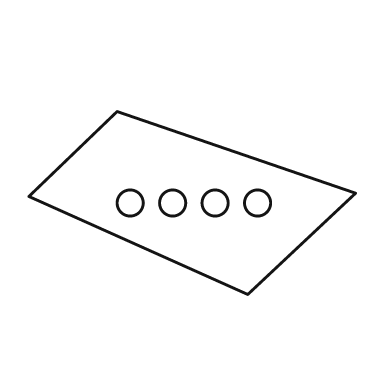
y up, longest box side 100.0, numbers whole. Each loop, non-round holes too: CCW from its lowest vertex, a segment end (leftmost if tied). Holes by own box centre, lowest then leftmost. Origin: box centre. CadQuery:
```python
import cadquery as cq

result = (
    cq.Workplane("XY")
    .moveTo(17.0, -28.0)
    .lineTo(50.0, 3.0)
    .lineTo(-23.0, 28.0)
    .lineTo(-50.0, 2.0)
    .close()
    .moveTo(-19.0, 0.0)
    .circle(4.0)
    .moveTo(-6.0, 0.0)
    .circle(4.0)
    .moveTo(7.0, 0.0)
    .circle(4.0)
    .moveTo(20.0, 0.0)
    .circle(4.0)
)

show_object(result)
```